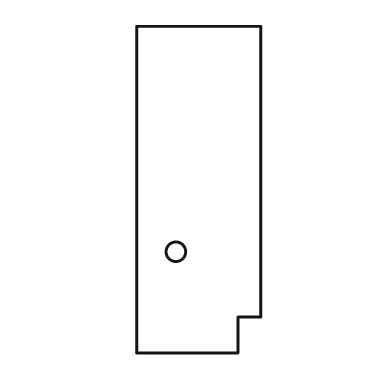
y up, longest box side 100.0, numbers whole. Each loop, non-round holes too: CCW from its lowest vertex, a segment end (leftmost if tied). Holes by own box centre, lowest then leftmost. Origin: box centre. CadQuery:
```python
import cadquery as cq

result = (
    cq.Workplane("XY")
    .moveTo(-19.0, -50.0)
    .lineTo(12.0, -50.0)
    .lineTo(12.0, -39.0)
    .lineTo(19.0, -39.0)
    .lineTo(19.0, 50.0)
    .lineTo(-19.0, 50.0)
    .close()
    .moveTo(-7.0, -19.0)
    .circle(3.0)
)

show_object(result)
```